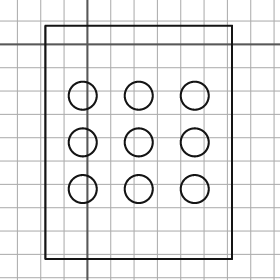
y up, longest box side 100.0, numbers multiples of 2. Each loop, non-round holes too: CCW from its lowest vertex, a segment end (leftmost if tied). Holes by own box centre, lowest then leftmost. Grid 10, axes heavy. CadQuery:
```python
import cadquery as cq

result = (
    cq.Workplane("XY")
    .moveTo(-18.0, -92.0)
    .lineTo(62.0, -92.0)
    .lineTo(62.0, 8.0)
    .lineTo(-18.0, 8.0)
    .close()
    .moveTo(-2.0, -62.0)
    .circle(6.0)
    .moveTo(22.0, -62.0)
    .circle(6.0)
    .moveTo(46.0, -62.0)
    .circle(6.0)
    .moveTo(-2.0, -42.0)
    .circle(6.0)
    .moveTo(22.0, -42.0)
    .circle(6.0)
    .moveTo(46.0, -42.0)
    .circle(6.0)
    .moveTo(-2.0, -22.0)
    .circle(6.0)
    .moveTo(22.0, -22.0)
    .circle(6.0)
    .moveTo(46.0, -22.0)
    .circle(6.0)
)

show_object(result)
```